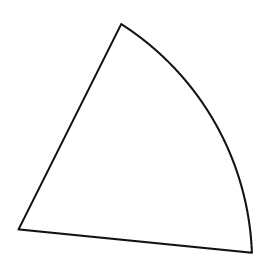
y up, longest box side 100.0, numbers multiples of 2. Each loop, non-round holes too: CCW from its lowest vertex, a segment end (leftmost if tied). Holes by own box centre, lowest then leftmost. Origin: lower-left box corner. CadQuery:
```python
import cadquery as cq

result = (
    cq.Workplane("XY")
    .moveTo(100.0, 0.0)
    .threePointArc((84.0, 56.0), (44.0, 98.0))
    .lineTo(0.0, 10.0)
    .close()
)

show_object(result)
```